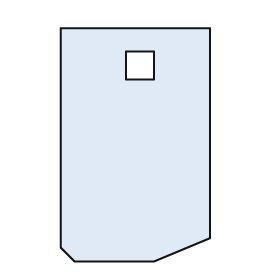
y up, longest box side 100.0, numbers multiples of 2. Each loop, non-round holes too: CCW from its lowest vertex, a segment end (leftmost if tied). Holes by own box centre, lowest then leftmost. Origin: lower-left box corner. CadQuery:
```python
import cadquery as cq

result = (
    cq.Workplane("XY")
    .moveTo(6.0, 0.0)
    .lineTo(40.0, 0.0)
    .lineTo(64.0, 10.0)
    .lineTo(64.0, 100.0)
    .lineTo(0.0, 100.0)
    .lineTo(0.0, 6.0)
    .close()
    .moveTo(28.0, 78.0)
    .lineTo(40.0, 78.0)
    .lineTo(40.0, 90.0)
    .lineTo(28.0, 90.0)
    .close()
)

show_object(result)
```